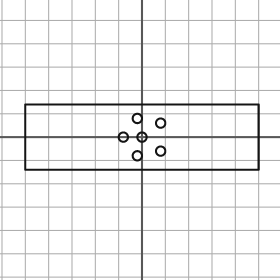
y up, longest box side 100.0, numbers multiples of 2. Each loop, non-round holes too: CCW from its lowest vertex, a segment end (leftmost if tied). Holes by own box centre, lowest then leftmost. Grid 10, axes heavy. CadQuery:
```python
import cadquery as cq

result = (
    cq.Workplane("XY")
    .moveTo(-50.0, -14.0)
    .lineTo(50.0, -14.0)
    .lineTo(50.0, 14.0)
    .lineTo(-50.0, 14.0)
    .close()
    .moveTo(-2.0, -8.0)
    .circle(2.0)
    .moveTo(8.0, -6.0)
    .circle(2.0)
    .moveTo(-8.0, 0.0)
    .circle(2.0)
    .moveTo(0.0, 0.0)
    .circle(2.0)
    .moveTo(8.0, 6.0)
    .circle(2.0)
    .moveTo(-2.0, 8.0)
    .circle(2.0)
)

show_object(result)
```